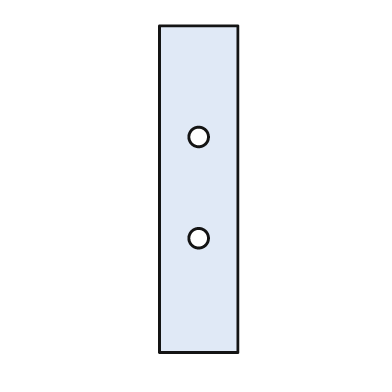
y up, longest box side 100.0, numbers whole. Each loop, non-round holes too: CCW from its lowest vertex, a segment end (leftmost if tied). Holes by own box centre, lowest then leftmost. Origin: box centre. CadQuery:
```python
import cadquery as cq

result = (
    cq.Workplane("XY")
    .moveTo(-12.0, -50.0)
    .lineTo(12.0, -50.0)
    .lineTo(12.0, 50.0)
    .lineTo(-12.0, 50.0)
    .close()
    .moveTo(0.0, -15.0)
    .circle(3.0)
    .moveTo(0.0, 16.0)
    .circle(3.0)
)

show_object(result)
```